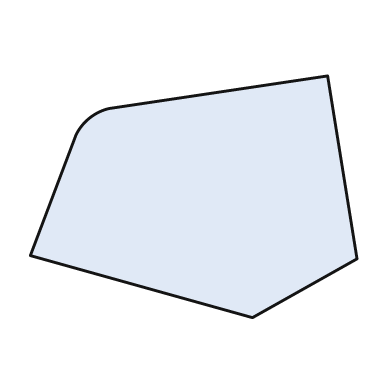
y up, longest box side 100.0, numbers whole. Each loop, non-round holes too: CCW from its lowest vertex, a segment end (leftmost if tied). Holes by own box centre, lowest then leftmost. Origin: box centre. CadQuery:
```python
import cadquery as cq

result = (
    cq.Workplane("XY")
    .moveTo(18.0, -37.0)
    .lineTo(50.0, -19.0)
    .lineTo(41.0, 37.0)
    .lineTo(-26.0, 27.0)
    .threePointArc((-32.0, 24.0), (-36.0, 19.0))
    .lineTo(-50.0, -18.0)
    .close()
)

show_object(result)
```